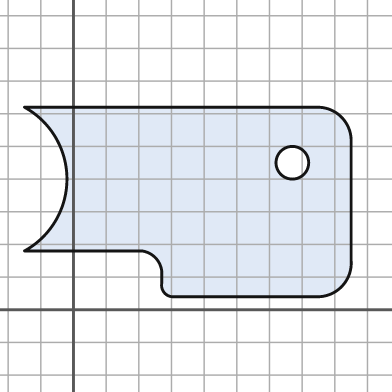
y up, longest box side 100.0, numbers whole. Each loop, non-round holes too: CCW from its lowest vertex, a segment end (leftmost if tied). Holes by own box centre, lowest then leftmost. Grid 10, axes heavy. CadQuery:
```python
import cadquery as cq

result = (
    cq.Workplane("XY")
    .moveTo(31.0, 4.0)
    .lineTo(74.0, 4.0)
    .threePointArc((82.0, 7.0), (85.0, 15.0))
    .lineTo(85.0, 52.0)
    .threePointArc((82.0, 59.0), (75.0, 62.0))
    .lineTo(-15.0, 62.0)
    .threePointArc((-2.0, 40.0), (-15.0, 18.0))
    .lineTo(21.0, 18.0)
    .threePointArc((25.0, 16.0), (27.0, 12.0))
    .lineTo(27.0, 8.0)
    .threePointArc((28.0, 5.0), (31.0, 4.0))
    .close()
    .moveTo(67.0, 45.0)
    .circle(5.0)
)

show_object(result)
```